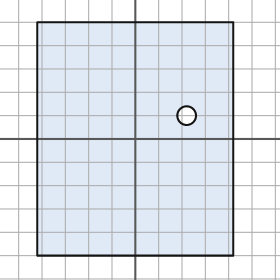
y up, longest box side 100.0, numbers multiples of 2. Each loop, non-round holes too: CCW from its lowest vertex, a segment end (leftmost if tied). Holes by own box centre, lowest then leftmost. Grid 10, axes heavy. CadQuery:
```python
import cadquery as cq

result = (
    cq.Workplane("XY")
    .moveTo(-42.0, -50.0)
    .lineTo(42.0, -50.0)
    .lineTo(42.0, 50.0)
    .lineTo(-42.0, 50.0)
    .close()
    .moveTo(22.0, 10.0)
    .circle(4.0)
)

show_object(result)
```